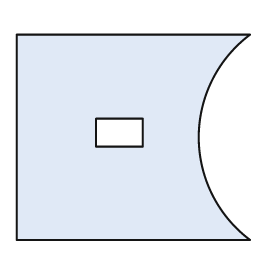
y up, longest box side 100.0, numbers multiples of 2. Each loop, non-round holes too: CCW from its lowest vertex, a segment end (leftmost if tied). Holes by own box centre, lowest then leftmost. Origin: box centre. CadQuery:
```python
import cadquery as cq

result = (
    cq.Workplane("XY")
    .moveTo(-50.0, -44.0)
    .lineTo(50.0, -44.0)
    .threePointArc((28.0, 0.0), (50.0, 44.0))
    .lineTo(-50.0, 44.0)
    .close()
    .moveTo(-16.0, -4.0)
    .lineTo(4.0, -4.0)
    .lineTo(4.0, 8.0)
    .lineTo(-16.0, 8.0)
    .close()
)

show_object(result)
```